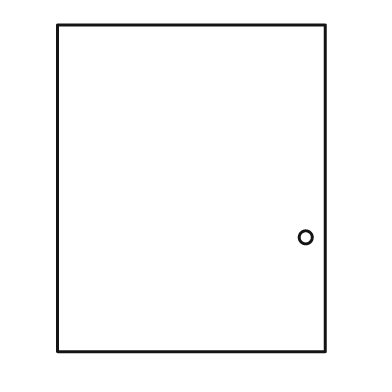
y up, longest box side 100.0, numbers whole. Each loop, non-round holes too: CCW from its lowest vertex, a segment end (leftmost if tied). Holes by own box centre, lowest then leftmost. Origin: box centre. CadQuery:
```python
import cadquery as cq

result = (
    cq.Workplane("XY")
    .moveTo(-41.0, -50.0)
    .lineTo(41.0, -50.0)
    .lineTo(41.0, 50.0)
    .lineTo(-41.0, 50.0)
    .close()
    .moveTo(35.0, -15.0)
    .circle(2.0)
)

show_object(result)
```